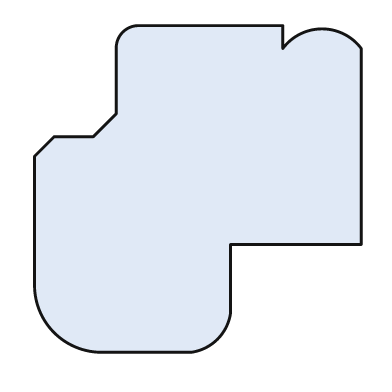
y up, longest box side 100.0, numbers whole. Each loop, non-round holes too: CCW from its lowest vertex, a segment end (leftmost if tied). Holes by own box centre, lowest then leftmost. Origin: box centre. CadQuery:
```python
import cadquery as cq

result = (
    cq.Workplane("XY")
    .moveTo(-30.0, -50.0)
    .lineTo(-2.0, -50.0)
    .threePointArc((6.0, -46.0), (10.0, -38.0))
    .lineTo(10.0, -17.0)
    .lineTo(50.0, -17.0)
    .lineTo(50.0, 43.0)
    .threePointArc((38.0, 49.0), (26.0, 43.0))
    .lineTo(26.0, 50.0)
    .lineTo(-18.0, 50.0)
    .threePointArc((-23.0, 48.0), (-25.0, 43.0))
    .lineTo(-25.0, 23.0)
    .lineTo(-32.0, 16.0)
    .lineTo(-44.0, 16.0)
    .lineTo(-50.0, 10.0)
    .lineTo(-50.0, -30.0)
    .threePointArc((-44.0, -44.0), (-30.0, -50.0))
    .close()
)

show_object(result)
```